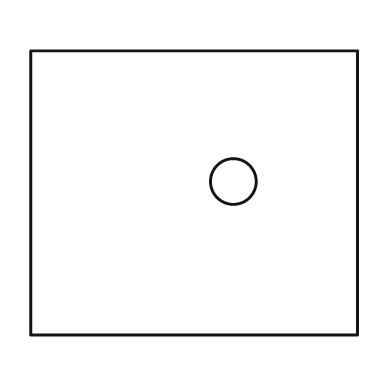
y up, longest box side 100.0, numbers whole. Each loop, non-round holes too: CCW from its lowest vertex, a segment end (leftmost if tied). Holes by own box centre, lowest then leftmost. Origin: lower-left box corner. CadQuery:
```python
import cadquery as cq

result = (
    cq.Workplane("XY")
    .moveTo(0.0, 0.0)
    .lineTo(100.0, 0.0)
    .lineTo(100.0, 87.0)
    .lineTo(0.0, 87.0)
    .close()
    .moveTo(62.0, 47.0)
    .circle(7.0)
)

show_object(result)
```